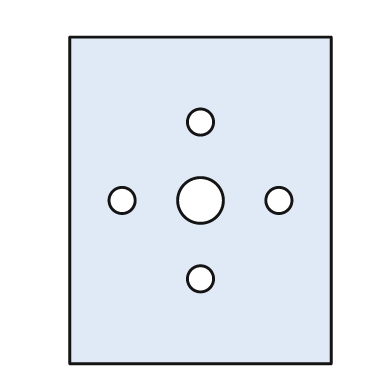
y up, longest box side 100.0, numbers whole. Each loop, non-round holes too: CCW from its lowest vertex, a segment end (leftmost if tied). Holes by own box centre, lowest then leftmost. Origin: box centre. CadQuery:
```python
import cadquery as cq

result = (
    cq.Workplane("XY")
    .moveTo(-40.0, -50.0)
    .lineTo(40.0, -50.0)
    .lineTo(40.0, 50.0)
    .lineTo(-40.0, 50.0)
    .close()
    .moveTo(0.0, -24.0)
    .circle(4.0)
    .moveTo(-24.0, 0.0)
    .circle(4.0)
    .moveTo(0.0, 0.0)
    .circle(7.0)
    .moveTo(24.0, 0.0)
    .circle(4.0)
    .moveTo(0.0, 24.0)
    .circle(4.0)
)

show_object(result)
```